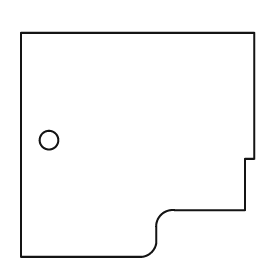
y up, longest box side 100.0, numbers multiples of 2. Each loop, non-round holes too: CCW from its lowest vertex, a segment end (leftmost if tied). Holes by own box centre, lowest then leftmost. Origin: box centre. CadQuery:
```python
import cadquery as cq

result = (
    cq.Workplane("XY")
    .moveTo(-50.0, -48.0)
    .lineTo(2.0, -48.0)
    .threePointArc((6.0, -46.0), (8.0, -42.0))
    .lineTo(8.0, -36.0)
    .threePointArc((10.0, -30.0), (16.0, -28.0))
    .lineTo(46.0, -28.0)
    .lineTo(46.0, -6.0)
    .lineTo(50.0, -6.0)
    .lineTo(50.0, 48.0)
    .lineTo(-50.0, 48.0)
    .close()
    .moveTo(-38.0, 2.0)
    .circle(4.0)
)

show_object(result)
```